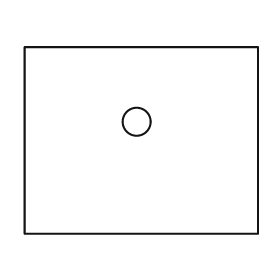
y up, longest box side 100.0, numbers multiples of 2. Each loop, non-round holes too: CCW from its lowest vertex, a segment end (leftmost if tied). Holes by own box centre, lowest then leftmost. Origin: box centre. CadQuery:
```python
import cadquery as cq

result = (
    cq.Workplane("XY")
    .moveTo(-50.0, -40.0)
    .lineTo(50.0, -40.0)
    .lineTo(50.0, 40.0)
    .lineTo(-50.0, 40.0)
    .close()
    .moveTo(-2.0, 8.0)
    .circle(6.0)
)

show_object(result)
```